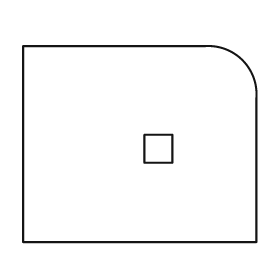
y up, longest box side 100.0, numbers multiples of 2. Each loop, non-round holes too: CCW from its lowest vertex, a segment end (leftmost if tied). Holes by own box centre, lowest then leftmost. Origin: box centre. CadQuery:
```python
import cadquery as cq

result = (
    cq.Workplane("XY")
    .moveTo(-50.0, -42.0)
    .lineTo(50.0, -42.0)
    .lineTo(50.0, 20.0)
    .threePointArc((44.0, 36.0), (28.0, 42.0))
    .lineTo(-50.0, 42.0)
    .close()
    .moveTo(2.0, -8.0)
    .lineTo(14.0, -8.0)
    .lineTo(14.0, 4.0)
    .lineTo(2.0, 4.0)
    .close()
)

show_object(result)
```